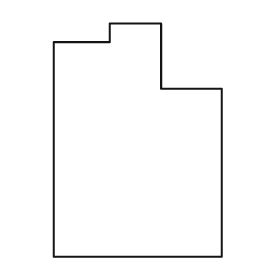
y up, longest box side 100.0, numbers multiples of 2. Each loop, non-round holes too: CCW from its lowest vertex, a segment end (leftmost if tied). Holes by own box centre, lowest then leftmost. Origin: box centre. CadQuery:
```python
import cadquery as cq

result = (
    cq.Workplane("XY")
    .moveTo(-36.0, -50.0)
    .lineTo(36.0, -50.0)
    .lineTo(36.0, 22.0)
    .lineTo(10.0, 22.0)
    .lineTo(10.0, 50.0)
    .lineTo(-12.0, 50.0)
    .lineTo(-12.0, 42.0)
    .lineTo(-36.0, 42.0)
    .close()
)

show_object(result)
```